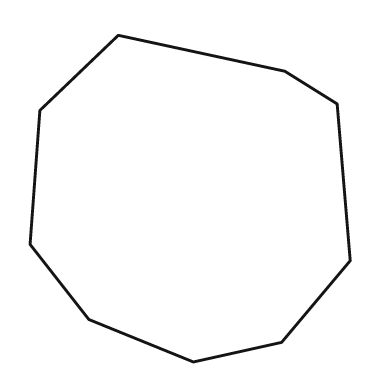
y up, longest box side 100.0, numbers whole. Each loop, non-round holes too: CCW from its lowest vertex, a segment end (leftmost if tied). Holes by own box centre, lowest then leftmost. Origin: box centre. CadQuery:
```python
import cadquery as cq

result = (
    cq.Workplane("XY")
    .moveTo(1.0, -50.0)
    .lineTo(28.0, -44.0)
    .lineTo(49.0, -19.0)
    .lineTo(45.0, 29.0)
    .lineTo(29.0, 39.0)
    .lineTo(-22.0, 50.0)
    .lineTo(-46.0, 27.0)
    .lineTo(-49.0, -14.0)
    .lineTo(-31.0, -37.0)
    .close()
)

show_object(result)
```